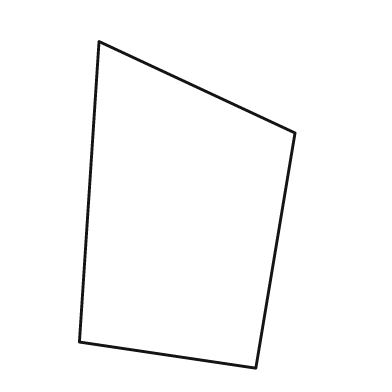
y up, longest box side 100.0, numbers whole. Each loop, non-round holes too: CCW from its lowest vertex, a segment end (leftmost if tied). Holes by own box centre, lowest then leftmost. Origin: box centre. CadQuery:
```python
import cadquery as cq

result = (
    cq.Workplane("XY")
    .moveTo(21.0, -50.0)
    .lineTo(33.0, 22.0)
    .lineTo(-27.0, 50.0)
    .lineTo(-33.0, -42.0)
    .close()
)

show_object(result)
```